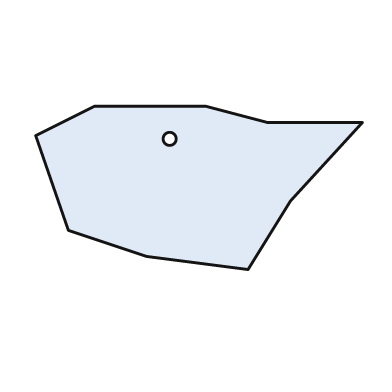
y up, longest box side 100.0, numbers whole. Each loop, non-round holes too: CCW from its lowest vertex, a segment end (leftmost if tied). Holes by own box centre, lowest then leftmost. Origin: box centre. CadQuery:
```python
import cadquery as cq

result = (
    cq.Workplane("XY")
    .moveTo(15.0, -25.0)
    .lineTo(28.0, -4.0)
    .lineTo(50.0, 20.0)
    .lineTo(21.0, 20.0)
    .lineTo(2.0, 25.0)
    .lineTo(-32.0, 25.0)
    .lineTo(-50.0, 16.0)
    .lineTo(-40.0, -13.0)
    .lineTo(-16.0, -21.0)
    .close()
    .moveTo(-9.0, 15.0)
    .circle(2.0)
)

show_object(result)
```